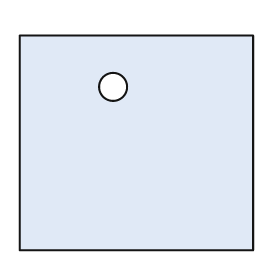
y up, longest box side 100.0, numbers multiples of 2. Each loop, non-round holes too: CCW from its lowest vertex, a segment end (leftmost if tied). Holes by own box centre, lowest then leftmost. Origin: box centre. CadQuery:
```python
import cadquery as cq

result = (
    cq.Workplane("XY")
    .moveTo(-50.0, -46.0)
    .lineTo(50.0, -46.0)
    .lineTo(50.0, 46.0)
    .lineTo(-50.0, 46.0)
    .close()
    .moveTo(-10.0, 24.0)
    .circle(6.0)
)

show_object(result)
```